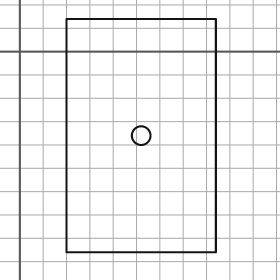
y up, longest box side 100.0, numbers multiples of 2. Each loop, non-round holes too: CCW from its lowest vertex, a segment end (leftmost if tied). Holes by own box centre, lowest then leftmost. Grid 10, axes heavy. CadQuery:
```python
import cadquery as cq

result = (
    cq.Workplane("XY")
    .moveTo(20.0, -86.0)
    .lineTo(84.0, -86.0)
    .lineTo(84.0, 14.0)
    .lineTo(20.0, 14.0)
    .close()
    .moveTo(52.0, -36.0)
    .circle(4.0)
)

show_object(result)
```